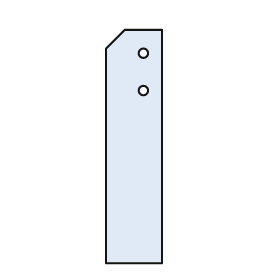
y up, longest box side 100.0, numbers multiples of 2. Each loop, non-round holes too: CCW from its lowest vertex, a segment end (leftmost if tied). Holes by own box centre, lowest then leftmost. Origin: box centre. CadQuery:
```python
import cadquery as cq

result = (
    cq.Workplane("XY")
    .moveTo(-12.0, -50.0)
    .lineTo(12.0, -50.0)
    .lineTo(12.0, 50.0)
    .lineTo(-4.0, 50.0)
    .lineTo(-12.0, 42.0)
    .close()
    .moveTo(4.0, 24.0)
    .circle(2.0)
    .moveTo(4.0, 40.0)
    .circle(2.0)
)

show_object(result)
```